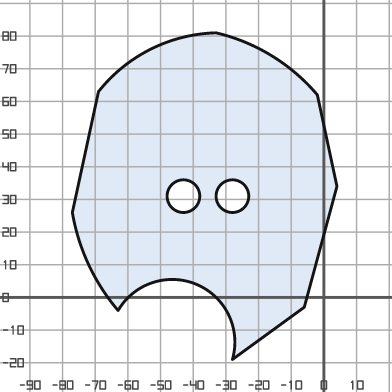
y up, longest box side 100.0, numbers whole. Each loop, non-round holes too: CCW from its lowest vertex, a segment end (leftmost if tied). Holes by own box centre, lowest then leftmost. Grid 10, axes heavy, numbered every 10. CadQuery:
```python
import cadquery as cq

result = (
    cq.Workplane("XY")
    .moveTo(-28.0, -19.0)
    .lineTo(-6.0, -3.0)
    .lineTo(4.0, 34.0)
    .lineTo(-2.0, 62.0)
    .threePointArc((-16.0, 74.0), (-33.0, 81.0))
    .threePointArc((-53.0, 76.0), (-69.0, 63.0))
    .lineTo(-77.0, 26.0)
    .threePointArc((-72.0, 10.0), (-63.0, -4.0))
    .threePointArc((-39.0, 4.0), (-28.0, -19.0))
    .close()
    .moveTo(-43.0, 31.0)
    .circle(5.0)
    .moveTo(-28.0, 31.0)
    .circle(5.0)
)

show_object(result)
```